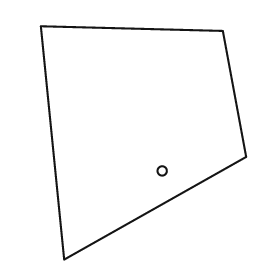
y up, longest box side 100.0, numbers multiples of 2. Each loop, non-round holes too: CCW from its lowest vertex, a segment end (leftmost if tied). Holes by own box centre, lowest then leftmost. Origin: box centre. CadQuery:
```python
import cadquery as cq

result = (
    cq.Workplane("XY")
    .moveTo(-34.0, -50.0)
    .lineTo(44.0, -6.0)
    .lineTo(34.0, 48.0)
    .lineTo(-44.0, 50.0)
    .close()
    .moveTo(8.0, -12.0)
    .circle(2.0)
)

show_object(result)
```